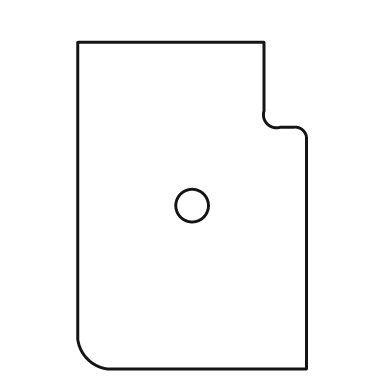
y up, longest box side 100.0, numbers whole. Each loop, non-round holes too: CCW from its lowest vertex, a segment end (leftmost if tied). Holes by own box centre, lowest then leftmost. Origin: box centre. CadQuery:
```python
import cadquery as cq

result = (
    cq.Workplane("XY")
    .moveTo(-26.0, -50.0)
    .lineTo(35.0, -50.0)
    .lineTo(35.0, 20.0)
    .threePointArc((34.0, 23.0), (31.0, 24.0))
    .lineTo(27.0, 24.0)
    .threePointArc((23.0, 25.0), (22.0, 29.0))
    .lineTo(22.0, 50.0)
    .lineTo(-35.0, 50.0)
    .lineTo(-35.0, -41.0)
    .threePointArc((-32.0, -47.0), (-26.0, -50.0))
    .close()
    .moveTo(0.0, 0.0)
    .circle(5.0)
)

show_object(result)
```